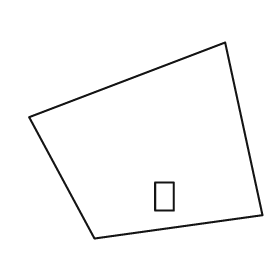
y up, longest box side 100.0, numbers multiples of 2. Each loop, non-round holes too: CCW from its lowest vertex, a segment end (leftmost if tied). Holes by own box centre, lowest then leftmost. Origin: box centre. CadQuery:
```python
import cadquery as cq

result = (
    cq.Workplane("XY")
    .moveTo(-22.0, -42.0)
    .lineTo(50.0, -32.0)
    .lineTo(34.0, 42.0)
    .lineTo(-50.0, 10.0)
    .close()
    .moveTo(4.0, -30.0)
    .lineTo(12.0, -30.0)
    .lineTo(12.0, -18.0)
    .lineTo(4.0, -18.0)
    .close()
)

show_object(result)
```